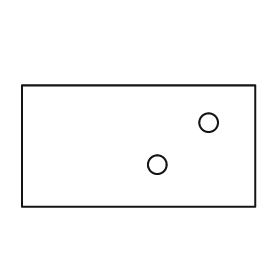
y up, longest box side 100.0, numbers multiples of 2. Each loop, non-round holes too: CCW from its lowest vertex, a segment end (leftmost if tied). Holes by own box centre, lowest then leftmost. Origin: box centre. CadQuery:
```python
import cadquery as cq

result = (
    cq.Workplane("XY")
    .moveTo(-50.0, -26.0)
    .lineTo(50.0, -26.0)
    .lineTo(50.0, 26.0)
    .lineTo(-50.0, 26.0)
    .close()
    .moveTo(8.0, -8.0)
    .circle(4.0)
    .moveTo(30.0, 10.0)
    .circle(4.0)
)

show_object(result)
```